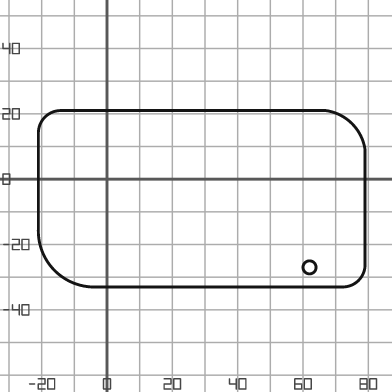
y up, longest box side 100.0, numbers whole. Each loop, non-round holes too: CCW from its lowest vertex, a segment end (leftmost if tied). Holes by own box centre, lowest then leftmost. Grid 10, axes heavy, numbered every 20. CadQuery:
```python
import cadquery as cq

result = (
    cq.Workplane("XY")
    .moveTo(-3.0, -33.0)
    .lineTo(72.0, -33.0)
    .threePointArc((77.0, -31.0), (79.0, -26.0))
    .lineTo(79.0, 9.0)
    .threePointArc((75.0, 17.0), (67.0, 21.0))
    .lineTo(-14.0, 21.0)
    .threePointArc((-19.0, 19.0), (-21.0, 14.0))
    .lineTo(-21.0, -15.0)
    .threePointArc((-16.0, -28.0), (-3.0, -33.0))
    .close()
    .moveTo(62.0, -27.0)
    .circle(2.0)
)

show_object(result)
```